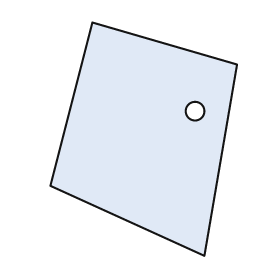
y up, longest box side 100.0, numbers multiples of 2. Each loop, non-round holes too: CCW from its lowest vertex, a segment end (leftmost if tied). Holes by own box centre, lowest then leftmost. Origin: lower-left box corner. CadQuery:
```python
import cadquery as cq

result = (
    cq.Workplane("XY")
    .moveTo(66.0, 0.0)
    .lineTo(80.0, 82.0)
    .lineTo(18.0, 100.0)
    .lineTo(0.0, 30.0)
    .close()
    .moveTo(62.0, 62.0)
    .circle(4.0)
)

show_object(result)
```